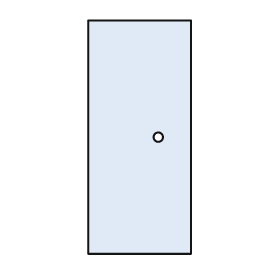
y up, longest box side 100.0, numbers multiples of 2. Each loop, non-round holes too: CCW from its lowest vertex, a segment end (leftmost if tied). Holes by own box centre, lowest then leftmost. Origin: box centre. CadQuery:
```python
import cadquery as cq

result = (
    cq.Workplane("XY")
    .moveTo(-22.0, -50.0)
    .lineTo(22.0, -50.0)
    .lineTo(22.0, 50.0)
    .lineTo(-22.0, 50.0)
    .close()
    .moveTo(8.0, 0.0)
    .circle(2.0)
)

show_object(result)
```